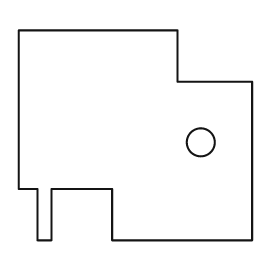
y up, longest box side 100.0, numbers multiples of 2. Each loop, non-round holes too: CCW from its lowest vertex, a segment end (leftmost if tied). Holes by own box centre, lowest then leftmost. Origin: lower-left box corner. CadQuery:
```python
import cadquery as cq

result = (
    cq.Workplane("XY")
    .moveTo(8.0, 0.0)
    .lineTo(14.0, 0.0)
    .lineTo(14.0, 22.0)
    .lineTo(40.0, 22.0)
    .lineTo(40.0, 0.0)
    .lineTo(100.0, 0.0)
    .lineTo(100.0, 68.0)
    .lineTo(68.0, 68.0)
    .lineTo(68.0, 90.0)
    .lineTo(0.0, 90.0)
    .lineTo(0.0, 22.0)
    .lineTo(8.0, 22.0)
    .close()
    .moveTo(78.0, 42.0)
    .circle(6.0)
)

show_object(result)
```